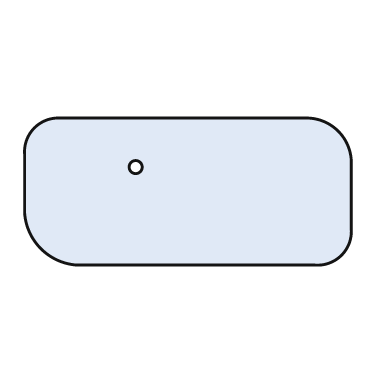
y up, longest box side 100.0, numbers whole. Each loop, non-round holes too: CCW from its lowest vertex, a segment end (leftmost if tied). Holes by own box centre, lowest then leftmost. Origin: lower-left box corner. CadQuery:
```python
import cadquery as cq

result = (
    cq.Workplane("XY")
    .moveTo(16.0, 0.0)
    .lineTo(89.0, 0.0)
    .threePointArc((97.0, 3.0), (100.0, 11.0))
    .lineTo(100.0, 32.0)
    .threePointArc((96.0, 41.0), (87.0, 45.0))
    .lineTo(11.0, 45.0)
    .threePointArc((3.0, 42.0), (0.0, 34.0))
    .lineTo(0.0, 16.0)
    .threePointArc((5.0, 5.0), (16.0, 0.0))
    .close()
    .moveTo(34.0, 30.0)
    .circle(2.0)
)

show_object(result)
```